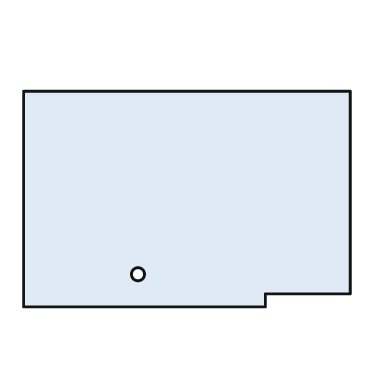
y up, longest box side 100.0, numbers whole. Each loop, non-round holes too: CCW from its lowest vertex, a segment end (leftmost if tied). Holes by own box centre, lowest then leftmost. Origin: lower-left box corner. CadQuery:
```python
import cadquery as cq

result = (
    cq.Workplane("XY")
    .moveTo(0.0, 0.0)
    .lineTo(74.0, 0.0)
    .lineTo(74.0, 4.0)
    .lineTo(100.0, 4.0)
    .lineTo(100.0, 66.0)
    .lineTo(0.0, 66.0)
    .close()
    .moveTo(35.0, 10.0)
    .circle(2.0)
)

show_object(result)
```